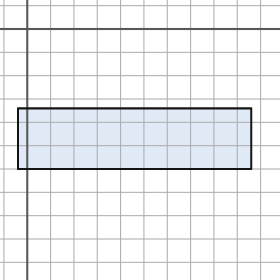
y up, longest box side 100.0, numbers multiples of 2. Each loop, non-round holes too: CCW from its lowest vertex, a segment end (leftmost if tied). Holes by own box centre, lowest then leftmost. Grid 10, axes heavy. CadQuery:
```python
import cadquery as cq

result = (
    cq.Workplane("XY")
    .moveTo(-4.0, -60.0)
    .lineTo(96.0, -60.0)
    .lineTo(96.0, -34.0)
    .lineTo(-4.0, -34.0)
    .close()
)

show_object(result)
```